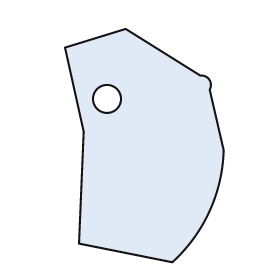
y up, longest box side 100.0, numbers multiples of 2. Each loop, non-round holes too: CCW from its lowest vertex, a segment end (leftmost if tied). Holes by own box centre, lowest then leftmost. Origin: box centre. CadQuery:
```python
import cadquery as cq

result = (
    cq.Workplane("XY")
    .moveTo(12.0, -50.0)
    .threePointArc((28.0, -28.0), (34.0, -2.0))
    .lineTo(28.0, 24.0)
    .threePointArc((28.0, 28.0), (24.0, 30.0))
    .lineTo(-8.0, 50.0)
    .lineTo(-34.0, 42.0)
    .lineTo(-26.0, 6.0)
    .lineTo(-28.0, -42.0)
    .close()
    .moveTo(-16.0, 20.0)
    .circle(6.0)
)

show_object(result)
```